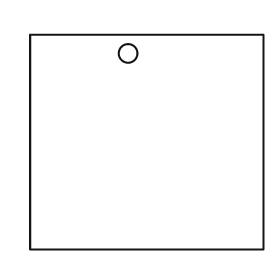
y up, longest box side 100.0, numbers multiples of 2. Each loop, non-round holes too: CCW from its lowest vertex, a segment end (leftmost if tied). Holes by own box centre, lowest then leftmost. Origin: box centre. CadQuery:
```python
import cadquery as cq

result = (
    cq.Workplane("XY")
    .moveTo(-50.0, -46.0)
    .lineTo(50.0, -46.0)
    .lineTo(50.0, 46.0)
    .lineTo(-50.0, 46.0)
    .close()
    .moveTo(-8.0, 38.0)
    .circle(4.0)
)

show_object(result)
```